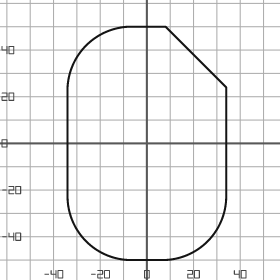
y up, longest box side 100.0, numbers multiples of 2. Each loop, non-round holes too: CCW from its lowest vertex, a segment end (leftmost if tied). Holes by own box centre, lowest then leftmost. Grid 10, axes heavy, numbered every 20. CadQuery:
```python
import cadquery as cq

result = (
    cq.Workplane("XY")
    .moveTo(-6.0, -50.0)
    .lineTo(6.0, -50.0)
    .threePointArc((26.0, -42.0), (34.0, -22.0))
    .lineTo(34.0, 24.0)
    .lineTo(8.0, 50.0)
    .lineTo(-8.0, 50.0)
    .threePointArc((-26.0, 42.0), (-34.0, 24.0))
    .lineTo(-34.0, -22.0)
    .threePointArc((-26.0, -42.0), (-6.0, -50.0))
    .close()
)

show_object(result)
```